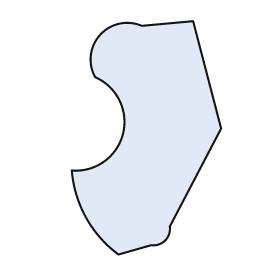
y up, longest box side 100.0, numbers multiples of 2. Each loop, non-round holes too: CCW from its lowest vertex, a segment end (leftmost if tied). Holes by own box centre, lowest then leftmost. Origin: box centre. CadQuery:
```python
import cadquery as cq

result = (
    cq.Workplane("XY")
    .moveTo(-12.0, -50.0)
    .lineTo(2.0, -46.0)
    .threePointArc((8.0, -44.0), (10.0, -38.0))
    .lineTo(32.0, 4.0)
    .lineTo(20.0, 50.0)
    .lineTo(-2.0, 48.0)
    .threePointArc((-20.0, 44.0), (-22.0, 26.0))
    .threePointArc((-10.0, 2.0), (-32.0, -14.0))
    .threePointArc((-26.0, -34.0), (-12.0, -50.0))
    .close()
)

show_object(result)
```